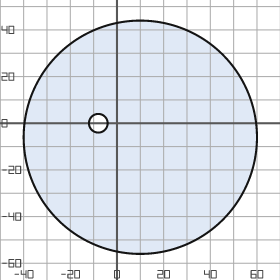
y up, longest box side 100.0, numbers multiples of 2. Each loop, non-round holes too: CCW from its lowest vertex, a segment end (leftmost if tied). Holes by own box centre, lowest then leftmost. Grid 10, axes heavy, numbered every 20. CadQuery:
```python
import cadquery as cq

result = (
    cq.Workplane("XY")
    .moveTo(10.0, -6.0)
    .circle(50.0)
    .moveTo(-8.0, 0.0)
    .circle(4.0)
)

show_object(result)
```